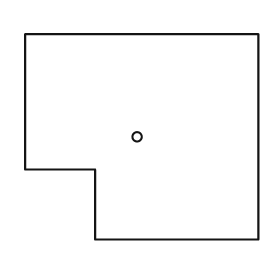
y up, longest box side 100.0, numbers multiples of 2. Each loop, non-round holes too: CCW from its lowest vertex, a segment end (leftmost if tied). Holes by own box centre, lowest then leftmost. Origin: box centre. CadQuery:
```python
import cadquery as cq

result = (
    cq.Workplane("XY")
    .moveTo(-20.0, -44.0)
    .lineTo(50.0, -44.0)
    .lineTo(50.0, 44.0)
    .lineTo(-50.0, 44.0)
    .lineTo(-50.0, -14.0)
    .lineTo(-20.0, -14.0)
    .close()
    .moveTo(-2.0, 0.0)
    .circle(2.0)
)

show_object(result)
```